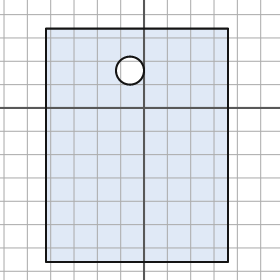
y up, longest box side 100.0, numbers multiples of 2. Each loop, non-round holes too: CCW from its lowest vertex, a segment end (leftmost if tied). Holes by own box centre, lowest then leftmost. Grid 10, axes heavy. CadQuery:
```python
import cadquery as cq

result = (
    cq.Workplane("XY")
    .moveTo(-42.0, -66.0)
    .lineTo(36.0, -66.0)
    .lineTo(36.0, 34.0)
    .lineTo(-42.0, 34.0)
    .close()
    .moveTo(-6.0, 16.0)
    .circle(6.0)
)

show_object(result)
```